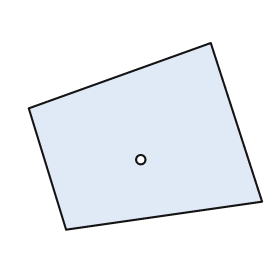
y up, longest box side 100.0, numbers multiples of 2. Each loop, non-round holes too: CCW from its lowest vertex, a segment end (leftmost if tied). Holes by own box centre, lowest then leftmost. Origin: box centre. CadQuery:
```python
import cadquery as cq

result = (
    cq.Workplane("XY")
    .moveTo(-34.0, -40.0)
    .lineTo(50.0, -28.0)
    .lineTo(28.0, 40.0)
    .lineTo(-50.0, 12.0)
    .close()
    .moveTo(-2.0, -10.0)
    .circle(2.0)
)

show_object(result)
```